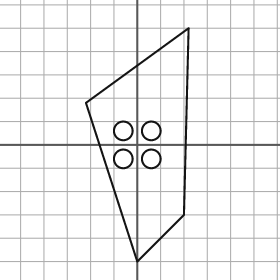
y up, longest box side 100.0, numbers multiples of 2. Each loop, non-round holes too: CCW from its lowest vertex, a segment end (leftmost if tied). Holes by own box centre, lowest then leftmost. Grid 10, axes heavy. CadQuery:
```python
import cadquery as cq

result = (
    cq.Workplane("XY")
    .moveTo(0.0, -50.0)
    .lineTo(20.0, -30.0)
    .lineTo(22.0, 50.0)
    .lineTo(-22.0, 18.0)
    .close()
    .moveTo(-6.0, -6.0)
    .circle(4.0)
    .moveTo(6.0, -6.0)
    .circle(4.0)
    .moveTo(-6.0, 6.0)
    .circle(4.0)
    .moveTo(6.0, 6.0)
    .circle(4.0)
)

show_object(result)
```